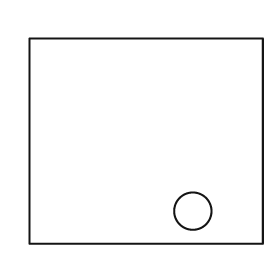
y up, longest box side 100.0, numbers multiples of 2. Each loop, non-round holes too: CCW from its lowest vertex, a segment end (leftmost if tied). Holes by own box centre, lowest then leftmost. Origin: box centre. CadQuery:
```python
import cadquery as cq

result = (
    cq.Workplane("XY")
    .moveTo(-50.0, -44.0)
    .lineTo(50.0, -44.0)
    .lineTo(50.0, 44.0)
    .lineTo(-50.0, 44.0)
    .close()
    .moveTo(20.0, -30.0)
    .circle(8.0)
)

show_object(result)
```